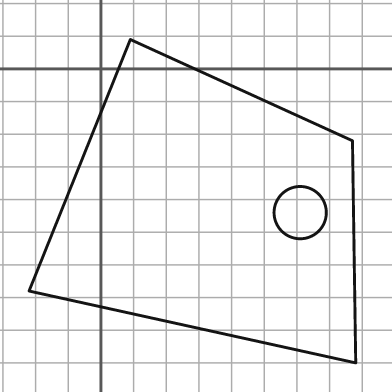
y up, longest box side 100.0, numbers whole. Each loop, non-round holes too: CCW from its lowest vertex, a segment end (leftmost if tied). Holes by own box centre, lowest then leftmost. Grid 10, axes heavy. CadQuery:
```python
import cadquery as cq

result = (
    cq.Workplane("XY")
    .moveTo(78.0, -90.0)
    .lineTo(77.0, -22.0)
    .lineTo(9.0, 9.0)
    .lineTo(-22.0, -68.0)
    .close()
    .moveTo(61.0, -44.0)
    .circle(8.0)
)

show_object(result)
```